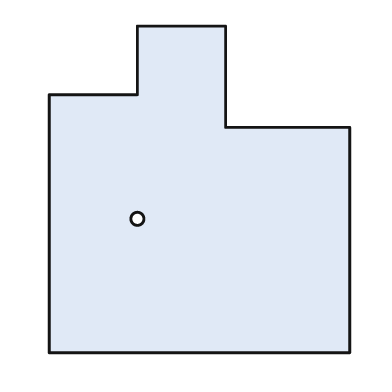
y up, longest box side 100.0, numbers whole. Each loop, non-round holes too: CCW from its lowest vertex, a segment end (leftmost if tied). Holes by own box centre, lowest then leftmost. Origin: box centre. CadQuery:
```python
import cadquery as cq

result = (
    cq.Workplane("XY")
    .moveTo(-46.0, -50.0)
    .lineTo(46.0, -50.0)
    .lineTo(46.0, 19.0)
    .lineTo(8.0, 19.0)
    .lineTo(8.0, 50.0)
    .lineTo(-19.0, 50.0)
    .lineTo(-19.0, 29.0)
    .lineTo(-46.0, 29.0)
    .close()
    .moveTo(-19.0, -9.0)
    .circle(2.0)
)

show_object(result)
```